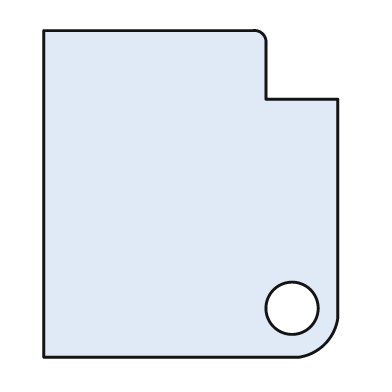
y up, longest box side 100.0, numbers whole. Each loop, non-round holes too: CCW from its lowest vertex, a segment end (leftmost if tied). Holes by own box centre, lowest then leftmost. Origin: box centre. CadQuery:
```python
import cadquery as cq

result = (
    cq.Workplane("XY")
    .moveTo(-45.0, -50.0)
    .lineTo(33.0, -50.0)
    .threePointArc((41.0, -46.0), (45.0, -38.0))
    .lineTo(45.0, 29.0)
    .lineTo(23.0, 29.0)
    .lineTo(23.0, 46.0)
    .threePointArc((22.0, 49.0), (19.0, 50.0))
    .lineTo(-45.0, 50.0)
    .close()
    .moveTo(31.0, -35.0)
    .circle(8.0)
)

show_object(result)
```